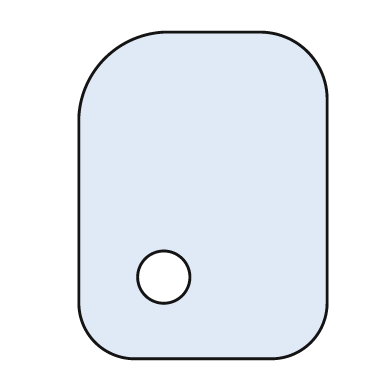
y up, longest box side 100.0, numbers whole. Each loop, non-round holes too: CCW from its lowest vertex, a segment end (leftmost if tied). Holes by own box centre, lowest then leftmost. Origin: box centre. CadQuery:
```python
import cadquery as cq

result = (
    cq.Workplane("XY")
    .moveTo(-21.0, -50.0)
    .lineTo(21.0, -50.0)
    .threePointArc((33.0, -45.0), (38.0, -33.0))
    .lineTo(38.0, 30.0)
    .threePointArc((32.0, 44.0), (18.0, 50.0))
    .lineTo(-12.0, 50.0)
    .threePointArc((-30.0, 42.0), (-38.0, 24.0))
    .lineTo(-38.0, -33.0)
    .threePointArc((-33.0, -45.0), (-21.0, -50.0))
    .close()
    .moveTo(-12.0, -25.0)
    .circle(8.0)
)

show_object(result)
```